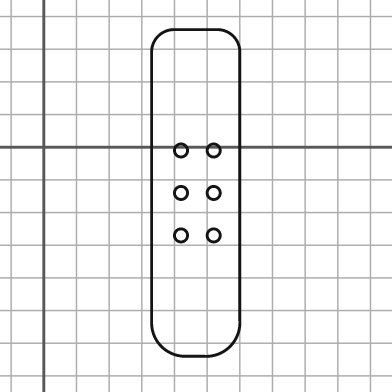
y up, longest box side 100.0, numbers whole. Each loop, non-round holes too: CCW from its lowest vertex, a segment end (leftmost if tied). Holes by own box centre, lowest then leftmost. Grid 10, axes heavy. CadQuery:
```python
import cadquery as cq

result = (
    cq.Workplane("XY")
    .moveTo(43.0, -64.0)
    .lineTo(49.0, -64.0)
    .threePointArc((57.0, -61.0), (60.0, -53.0))
    .lineTo(60.0, 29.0)
    .threePointArc((58.0, 34.0), (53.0, 36.0))
    .lineTo(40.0, 36.0)
    .threePointArc((35.0, 34.0), (33.0, 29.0))
    .lineTo(33.0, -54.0)
    .threePointArc((36.0, -61.0), (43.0, -64.0))
    .close()
    .moveTo(42.0, -27.0)
    .circle(2.0)
    .moveTo(52.0, -27.0)
    .circle(2.0)
    .moveTo(42.0, -14.0)
    .circle(2.0)
    .moveTo(52.0, -14.0)
    .circle(2.0)
    .moveTo(42.0, -1.0)
    .circle(2.0)
    .moveTo(52.0, -1.0)
    .circle(2.0)
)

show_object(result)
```